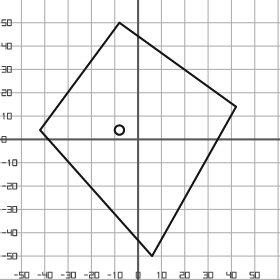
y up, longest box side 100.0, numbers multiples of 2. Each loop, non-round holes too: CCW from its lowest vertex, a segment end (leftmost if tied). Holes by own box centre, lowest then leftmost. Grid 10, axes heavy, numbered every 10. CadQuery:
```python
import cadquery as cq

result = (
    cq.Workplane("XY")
    .moveTo(6.0, -50.0)
    .lineTo(42.0, 14.0)
    .lineTo(-8.0, 50.0)
    .lineTo(-42.0, 4.0)
    .close()
    .moveTo(-8.0, 4.0)
    .circle(2.0)
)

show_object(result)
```